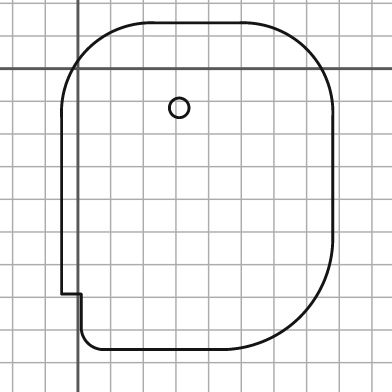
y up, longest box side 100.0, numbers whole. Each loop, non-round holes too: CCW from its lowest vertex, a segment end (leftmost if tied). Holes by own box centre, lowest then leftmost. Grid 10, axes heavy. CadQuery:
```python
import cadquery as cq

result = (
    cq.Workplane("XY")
    .moveTo(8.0, -86.0)
    .lineTo(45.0, -86.0)
    .threePointArc((68.0, -76.0), (78.0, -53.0))
    .lineTo(78.0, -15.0)
    .threePointArc((70.0, 6.0), (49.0, 14.0))
    .lineTo(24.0, 14.0)
    .threePointArc((3.0, 6.0), (-5.0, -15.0))
    .lineTo(-5.0, -69.0)
    .lineTo(1.0, -69.0)
    .lineTo(1.0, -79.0)
    .threePointArc((3.0, -84.0), (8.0, -86.0))
    .close()
    .moveTo(31.0, -12.0)
    .circle(3.0)
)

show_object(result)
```